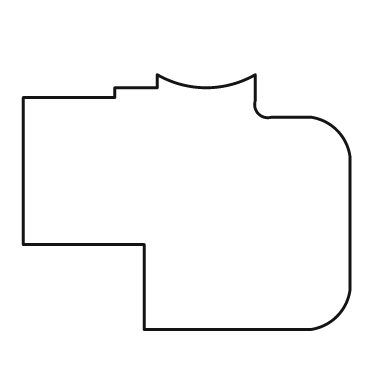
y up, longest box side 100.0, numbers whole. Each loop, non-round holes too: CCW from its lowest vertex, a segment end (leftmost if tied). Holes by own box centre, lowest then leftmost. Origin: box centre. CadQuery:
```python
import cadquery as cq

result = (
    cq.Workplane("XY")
    .moveTo(-13.0, -39.0)
    .lineTo(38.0, -39.0)
    .threePointArc((46.0, -35.0), (50.0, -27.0))
    .lineTo(50.0, 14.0)
    .threePointArc((46.0, 22.0), (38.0, 26.0))
    .lineTo(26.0, 26.0)
    .threePointArc((22.0, 27.0), (21.0, 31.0))
    .lineTo(21.0, 39.0)
    .threePointArc((6.0, 35.0), (-9.0, 39.0))
    .lineTo(-9.0, 35.0)
    .lineTo(-22.0, 35.0)
    .lineTo(-22.0, 32.0)
    .lineTo(-50.0, 32.0)
    .lineTo(-50.0, -13.0)
    .lineTo(-13.0, -13.0)
    .close()
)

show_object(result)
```